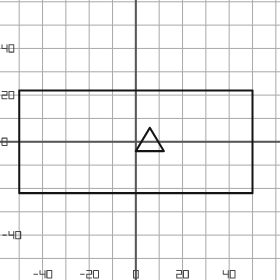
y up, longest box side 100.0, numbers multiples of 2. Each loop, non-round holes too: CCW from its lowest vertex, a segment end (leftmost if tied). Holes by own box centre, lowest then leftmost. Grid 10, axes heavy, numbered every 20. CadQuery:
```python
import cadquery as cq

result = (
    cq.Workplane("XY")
    .moveTo(-50.0, -22.0)
    .lineTo(50.0, -22.0)
    .lineTo(50.0, 22.0)
    .lineTo(-50.0, 22.0)
    .close()
    .moveTo(0.0, -4.0)
    .lineTo(12.0, -4.0)
    .lineTo(6.0, 6.0)
    .close()
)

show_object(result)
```